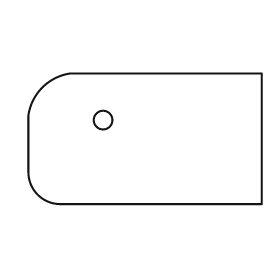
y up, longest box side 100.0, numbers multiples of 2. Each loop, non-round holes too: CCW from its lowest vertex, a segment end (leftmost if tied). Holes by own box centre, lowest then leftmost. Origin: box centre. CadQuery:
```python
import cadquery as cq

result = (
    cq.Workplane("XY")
    .moveTo(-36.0, -28.0)
    .lineTo(50.0, -28.0)
    .lineTo(50.0, 28.0)
    .lineTo(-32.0, 28.0)
    .threePointArc((-44.0, 22.0), (-50.0, 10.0))
    .lineTo(-50.0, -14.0)
    .threePointArc((-46.0, -24.0), (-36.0, -28.0))
    .close()
    .moveTo(-18.0, 8.0)
    .circle(4.0)
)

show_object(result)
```